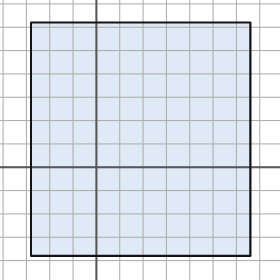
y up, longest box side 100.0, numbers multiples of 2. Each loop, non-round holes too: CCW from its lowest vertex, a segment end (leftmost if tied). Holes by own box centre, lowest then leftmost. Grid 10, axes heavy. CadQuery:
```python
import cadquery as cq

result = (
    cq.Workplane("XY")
    .moveTo(-28.0, -38.0)
    .lineTo(66.0, -38.0)
    .lineTo(66.0, 62.0)
    .lineTo(-28.0, 62.0)
    .close()
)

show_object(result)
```